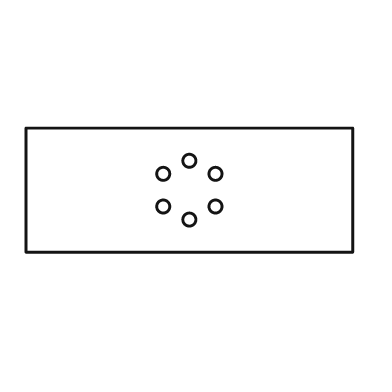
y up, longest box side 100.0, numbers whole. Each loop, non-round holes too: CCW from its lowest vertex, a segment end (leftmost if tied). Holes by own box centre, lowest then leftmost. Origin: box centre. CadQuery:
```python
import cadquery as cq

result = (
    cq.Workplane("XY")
    .moveTo(-50.0, -19.0)
    .lineTo(50.0, -19.0)
    .lineTo(50.0, 19.0)
    .lineTo(-50.0, 19.0)
    .close()
    .moveTo(0.0, -9.0)
    .circle(2.0)
    .moveTo(-8.0, -5.0)
    .circle(2.0)
    .moveTo(8.0, -5.0)
    .circle(2.0)
    .moveTo(-8.0, 5.0)
    .circle(2.0)
    .moveTo(8.0, 5.0)
    .circle(2.0)
    .moveTo(0.0, 9.0)
    .circle(2.0)
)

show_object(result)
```